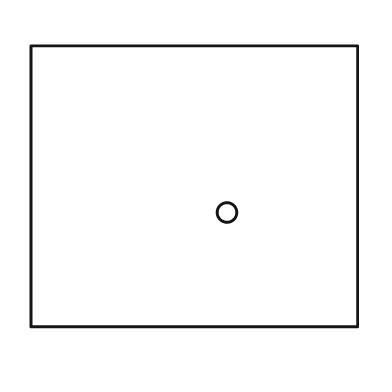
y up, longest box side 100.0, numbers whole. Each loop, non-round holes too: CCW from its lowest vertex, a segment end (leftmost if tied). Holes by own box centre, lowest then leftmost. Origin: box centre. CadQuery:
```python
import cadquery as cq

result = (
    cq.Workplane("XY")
    .moveTo(-50.0, -43.0)
    .lineTo(50.0, -43.0)
    .lineTo(50.0, 43.0)
    .lineTo(-50.0, 43.0)
    .close()
    .moveTo(10.0, -8.0)
    .circle(3.0)
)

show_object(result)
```